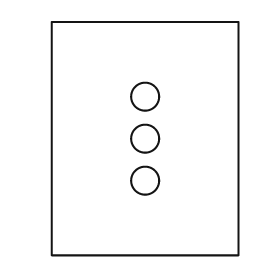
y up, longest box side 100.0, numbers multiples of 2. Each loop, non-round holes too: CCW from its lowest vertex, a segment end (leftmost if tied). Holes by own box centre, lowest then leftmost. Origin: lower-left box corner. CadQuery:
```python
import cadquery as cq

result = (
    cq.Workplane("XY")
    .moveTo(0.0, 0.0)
    .lineTo(80.0, 0.0)
    .lineTo(80.0, 100.0)
    .lineTo(0.0, 100.0)
    .close()
    .moveTo(40.0, 32.0)
    .circle(6.0)
    .moveTo(40.0, 50.0)
    .circle(6.0)
    .moveTo(40.0, 68.0)
    .circle(6.0)
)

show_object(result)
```